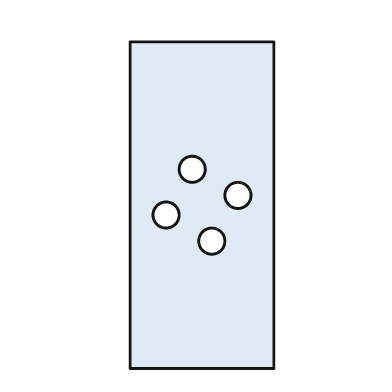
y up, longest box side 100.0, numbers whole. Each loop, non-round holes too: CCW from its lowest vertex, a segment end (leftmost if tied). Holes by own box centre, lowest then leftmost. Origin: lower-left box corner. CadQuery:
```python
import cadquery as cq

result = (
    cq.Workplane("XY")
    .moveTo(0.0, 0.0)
    .lineTo(44.0, 0.0)
    .lineTo(44.0, 100.0)
    .lineTo(0.0, 100.0)
    .close()
    .moveTo(25.0, 39.0)
    .circle(4.0)
    .moveTo(11.0, 47.0)
    .circle(4.0)
    .moveTo(33.0, 53.0)
    .circle(4.0)
    .moveTo(19.0, 61.0)
    .circle(4.0)
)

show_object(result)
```